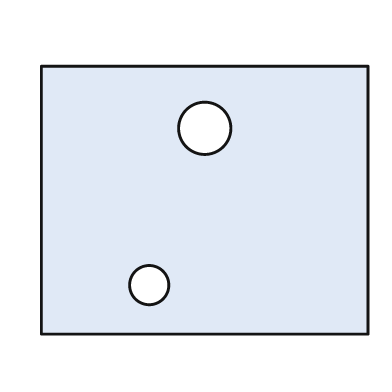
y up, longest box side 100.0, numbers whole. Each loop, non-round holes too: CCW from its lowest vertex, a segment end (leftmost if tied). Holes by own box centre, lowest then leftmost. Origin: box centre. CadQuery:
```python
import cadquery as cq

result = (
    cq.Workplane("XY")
    .moveTo(-50.0, -41.0)
    .lineTo(50.0, -41.0)
    .lineTo(50.0, 41.0)
    .lineTo(-50.0, 41.0)
    .close()
    .moveTo(-17.0, -26.0)
    .circle(6.0)
    .moveTo(0.0, 22.0)
    .circle(8.0)
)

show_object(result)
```